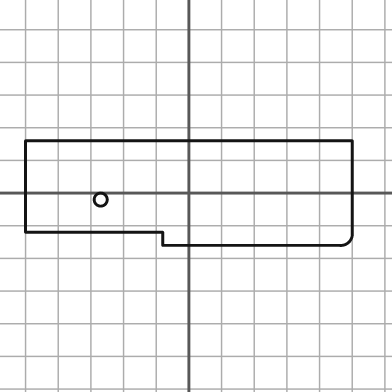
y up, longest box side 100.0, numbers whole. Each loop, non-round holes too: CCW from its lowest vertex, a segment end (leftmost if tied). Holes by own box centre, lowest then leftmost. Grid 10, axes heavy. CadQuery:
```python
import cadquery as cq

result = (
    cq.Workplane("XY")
    .moveTo(-8.0, -16.0)
    .lineTo(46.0, -16.0)
    .threePointArc((49.0, -15.0), (50.0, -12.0))
    .lineTo(50.0, 16.0)
    .lineTo(-50.0, 16.0)
    .lineTo(-50.0, -12.0)
    .lineTo(-8.0, -12.0)
    .close()
    .moveTo(-27.0, -2.0)
    .circle(2.0)
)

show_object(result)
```